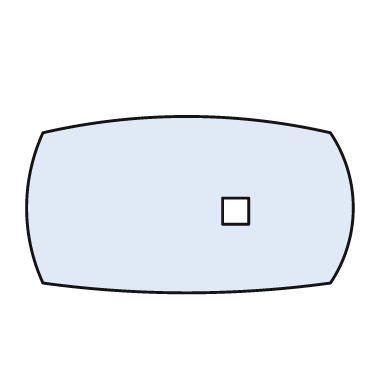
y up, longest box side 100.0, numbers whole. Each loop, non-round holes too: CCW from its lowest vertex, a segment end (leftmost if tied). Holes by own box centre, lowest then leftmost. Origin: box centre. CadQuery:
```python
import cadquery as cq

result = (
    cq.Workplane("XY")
    .moveTo(-45.0, -24.0)
    .threePointArc((-1.0, -27.0), (43.0, -24.0))
    .threePointArc((50.0, -1.0), (43.0, 22.0))
    .threePointArc((-1.0, 27.0), (-45.0, 22.0))
    .threePointArc((-50.0, -1.0), (-45.0, -24.0))
    .close()
    .moveTo(10.0, -6.0)
    .lineTo(18.0, -6.0)
    .lineTo(18.0, 2.0)
    .lineTo(10.0, 2.0)
    .close()
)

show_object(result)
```